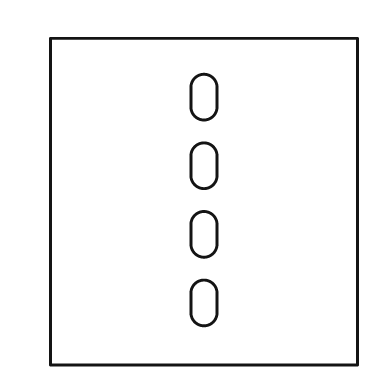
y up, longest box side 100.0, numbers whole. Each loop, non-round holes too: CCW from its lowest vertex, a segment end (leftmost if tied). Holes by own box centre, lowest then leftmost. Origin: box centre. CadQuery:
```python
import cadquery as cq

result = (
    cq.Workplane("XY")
    .moveTo(-47.0, -50.0)
    .lineTo(47.0, -50.0)
    .lineTo(47.0, 50.0)
    .lineTo(-47.0, 50.0)
    .close()
    .moveTo(-4.0, -34.0)
    .threePointArc((0.0, -38.0), (4.0, -34.0))
    .lineTo(4.0, -28.0)
    .threePointArc((0.0, -24.0), (-4.0, -28.0))
    .close()
    .moveTo(-4.0, -13.0)
    .threePointArc((0.0, -17.0), (4.0, -13.0))
    .lineTo(4.0, -7.0)
    .threePointArc((0.0, -3.0), (-4.0, -7.0))
    .close()
    .moveTo(-4.0, 8.0)
    .threePointArc((0.0, 4.0), (4.0, 8.0))
    .lineTo(4.0, 14.0)
    .threePointArc((0.0, 18.0), (-4.0, 14.0))
    .close()
    .moveTo(-4.0, 29.0)
    .threePointArc((0.0, 25.0), (4.0, 29.0))
    .lineTo(4.0, 35.0)
    .threePointArc((0.0, 39.0), (-4.0, 35.0))
    .close()
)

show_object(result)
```